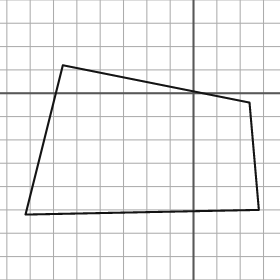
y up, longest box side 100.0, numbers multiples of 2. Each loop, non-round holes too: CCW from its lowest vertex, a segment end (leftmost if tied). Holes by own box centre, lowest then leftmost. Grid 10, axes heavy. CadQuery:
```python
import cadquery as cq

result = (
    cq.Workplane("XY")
    .moveTo(-72.0, -52.0)
    .lineTo(28.0, -50.0)
    .lineTo(24.0, -4.0)
    .lineTo(-56.0, 12.0)
    .close()
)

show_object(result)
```